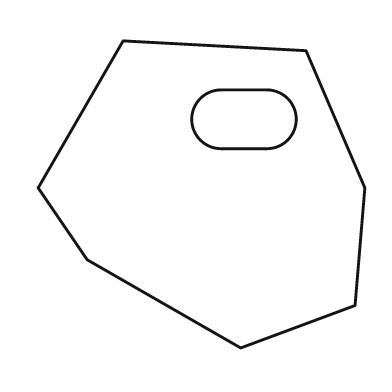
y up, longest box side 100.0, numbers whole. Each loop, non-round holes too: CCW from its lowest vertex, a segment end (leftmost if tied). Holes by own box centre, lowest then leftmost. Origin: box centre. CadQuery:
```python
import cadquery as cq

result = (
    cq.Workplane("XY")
    .moveTo(12.0, -47.0)
    .lineTo(47.0, -34.0)
    .lineTo(50.0, 2.0)
    .lineTo(32.0, 44.0)
    .lineTo(-24.0, 47.0)
    .lineTo(-50.0, 2.0)
    .lineTo(-35.0, -20.0)
    .close()
    .moveTo(6.0, 14.0)
    .lineTo(20.0, 14.0)
    .threePointArc((29.0, 23.0), (20.0, 32.0))
    .lineTo(6.0, 32.0)
    .threePointArc((-3.0, 23.0), (6.0, 14.0))
    .close()
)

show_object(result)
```